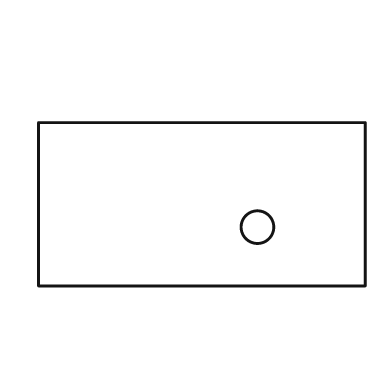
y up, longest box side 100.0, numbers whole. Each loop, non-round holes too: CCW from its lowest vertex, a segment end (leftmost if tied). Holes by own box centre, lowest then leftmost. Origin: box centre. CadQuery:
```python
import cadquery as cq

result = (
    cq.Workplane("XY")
    .moveTo(-50.0, -25.0)
    .lineTo(50.0, -25.0)
    .lineTo(50.0, 25.0)
    .lineTo(-50.0, 25.0)
    .close()
    .moveTo(17.0, -7.0)
    .circle(5.0)
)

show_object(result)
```